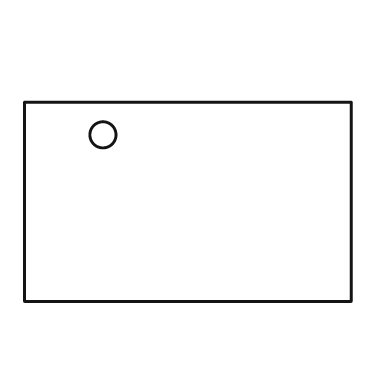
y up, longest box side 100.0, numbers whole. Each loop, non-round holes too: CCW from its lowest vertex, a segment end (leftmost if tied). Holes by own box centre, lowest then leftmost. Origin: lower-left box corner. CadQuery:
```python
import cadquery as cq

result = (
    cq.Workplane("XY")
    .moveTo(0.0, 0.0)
    .lineTo(100.0, 0.0)
    .lineTo(100.0, 61.0)
    .lineTo(0.0, 61.0)
    .close()
    .moveTo(24.0, 51.0)
    .circle(4.0)
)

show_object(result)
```